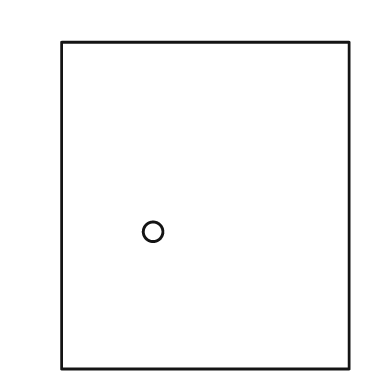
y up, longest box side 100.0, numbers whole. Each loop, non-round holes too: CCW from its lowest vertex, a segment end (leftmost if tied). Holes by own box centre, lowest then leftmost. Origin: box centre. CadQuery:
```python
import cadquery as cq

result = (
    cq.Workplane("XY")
    .moveTo(-44.0, -50.0)
    .lineTo(44.0, -50.0)
    .lineTo(44.0, 50.0)
    .lineTo(-44.0, 50.0)
    .close()
    .moveTo(-16.0, -8.0)
    .circle(3.0)
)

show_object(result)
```